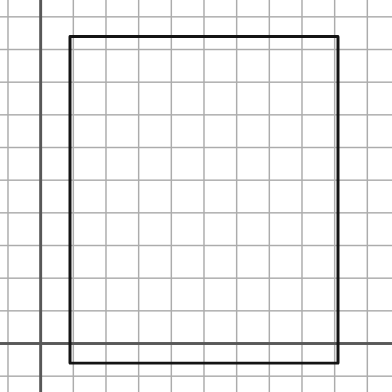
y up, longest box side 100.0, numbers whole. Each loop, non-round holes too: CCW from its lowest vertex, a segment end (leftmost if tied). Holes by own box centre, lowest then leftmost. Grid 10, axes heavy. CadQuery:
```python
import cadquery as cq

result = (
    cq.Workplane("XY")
    .moveTo(9.0, -6.0)
    .lineTo(91.0, -6.0)
    .lineTo(91.0, 94.0)
    .lineTo(9.0, 94.0)
    .close()
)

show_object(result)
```